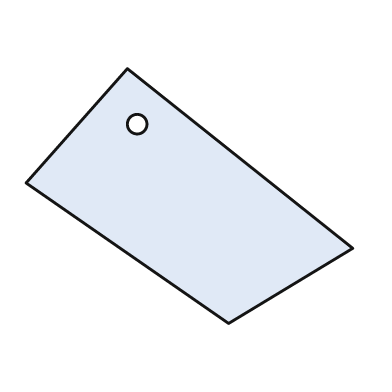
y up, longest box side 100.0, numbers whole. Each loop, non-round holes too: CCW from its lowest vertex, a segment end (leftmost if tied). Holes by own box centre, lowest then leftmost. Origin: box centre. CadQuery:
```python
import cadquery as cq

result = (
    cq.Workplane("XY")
    .moveTo(12.0, -39.0)
    .lineTo(50.0, -16.0)
    .lineTo(-19.0, 39.0)
    .lineTo(-50.0, 4.0)
    .close()
    .moveTo(-16.0, 22.0)
    .circle(3.0)
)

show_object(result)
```